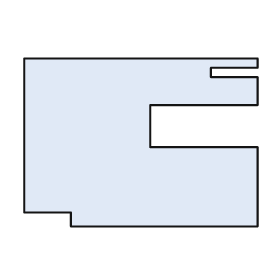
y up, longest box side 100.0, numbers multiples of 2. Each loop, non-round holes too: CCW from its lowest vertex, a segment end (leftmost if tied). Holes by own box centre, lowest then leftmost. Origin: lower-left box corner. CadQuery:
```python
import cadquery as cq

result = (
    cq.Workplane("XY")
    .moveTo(20.0, 0.0)
    .lineTo(100.0, 0.0)
    .lineTo(100.0, 34.0)
    .lineTo(54.0, 34.0)
    .lineTo(54.0, 52.0)
    .lineTo(100.0, 52.0)
    .lineTo(100.0, 64.0)
    .lineTo(80.0, 64.0)
    .lineTo(80.0, 68.0)
    .lineTo(100.0, 68.0)
    .lineTo(100.0, 72.0)
    .lineTo(0.0, 72.0)
    .lineTo(0.0, 6.0)
    .lineTo(20.0, 6.0)
    .close()
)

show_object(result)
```